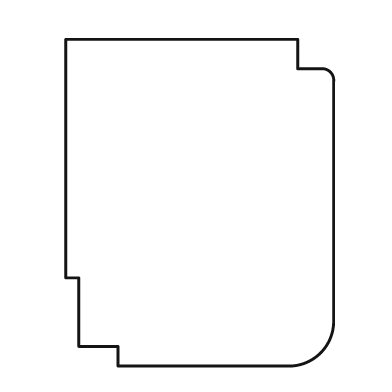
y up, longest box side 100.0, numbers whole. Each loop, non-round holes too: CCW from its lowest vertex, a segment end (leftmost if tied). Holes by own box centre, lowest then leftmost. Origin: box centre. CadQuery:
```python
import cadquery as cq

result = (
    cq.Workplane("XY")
    .moveTo(-25.0, -50.0)
    .lineTo(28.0, -50.0)
    .threePointArc((37.0, -46.0), (41.0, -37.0))
    .lineTo(41.0, 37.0)
    .threePointArc((40.0, 40.0), (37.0, 41.0))
    .lineTo(30.0, 41.0)
    .lineTo(30.0, 50.0)
    .lineTo(-41.0, 50.0)
    .lineTo(-41.0, -23.0)
    .lineTo(-37.0, -23.0)
    .lineTo(-37.0, -44.0)
    .lineTo(-25.0, -44.0)
    .close()
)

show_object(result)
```